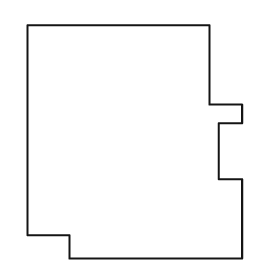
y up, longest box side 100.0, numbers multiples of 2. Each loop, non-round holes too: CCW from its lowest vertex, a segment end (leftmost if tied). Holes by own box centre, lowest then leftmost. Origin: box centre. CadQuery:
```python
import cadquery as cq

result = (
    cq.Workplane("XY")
    .moveTo(-28.0, -50.0)
    .lineTo(46.0, -50.0)
    .lineTo(46.0, -16.0)
    .lineTo(36.0, -16.0)
    .lineTo(36.0, 8.0)
    .lineTo(46.0, 8.0)
    .lineTo(46.0, 16.0)
    .lineTo(32.0, 16.0)
    .lineTo(32.0, 50.0)
    .lineTo(-46.0, 50.0)
    .lineTo(-46.0, -40.0)
    .lineTo(-28.0, -40.0)
    .close()
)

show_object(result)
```